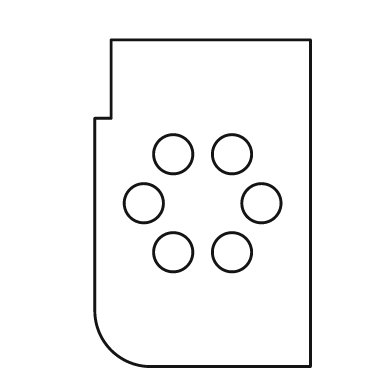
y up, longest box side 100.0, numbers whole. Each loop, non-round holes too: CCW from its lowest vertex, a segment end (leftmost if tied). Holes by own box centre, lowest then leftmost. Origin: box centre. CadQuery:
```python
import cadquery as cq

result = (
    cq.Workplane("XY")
    .moveTo(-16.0, -50.0)
    .lineTo(33.0, -50.0)
    .lineTo(33.0, 50.0)
    .lineTo(-28.0, 50.0)
    .lineTo(-28.0, 26.0)
    .lineTo(-33.0, 26.0)
    .lineTo(-33.0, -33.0)
    .threePointArc((-28.0, -45.0), (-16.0, -50.0))
    .close()
    .moveTo(-9.0, -15.0)
    .circle(6.0)
    .moveTo(9.0, -15.0)
    .circle(6.0)
    .moveTo(-18.0, 0.0)
    .circle(6.0)
    .moveTo(18.0, 0.0)
    .circle(6.0)
    .moveTo(-9.0, 15.0)
    .circle(6.0)
    .moveTo(9.0, 15.0)
    .circle(6.0)
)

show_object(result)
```